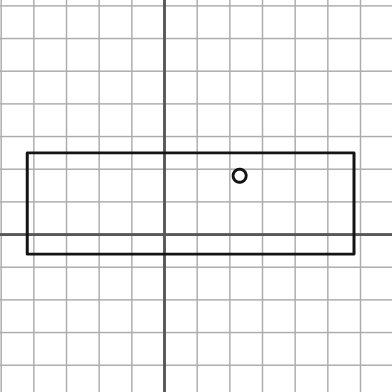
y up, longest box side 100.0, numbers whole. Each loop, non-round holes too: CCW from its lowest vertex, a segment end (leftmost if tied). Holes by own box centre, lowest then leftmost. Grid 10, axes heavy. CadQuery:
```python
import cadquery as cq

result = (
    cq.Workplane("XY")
    .moveTo(-42.0, -6.0)
    .lineTo(58.0, -6.0)
    .lineTo(58.0, 25.0)
    .lineTo(-42.0, 25.0)
    .close()
    .moveTo(23.0, 18.0)
    .circle(2.0)
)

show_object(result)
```